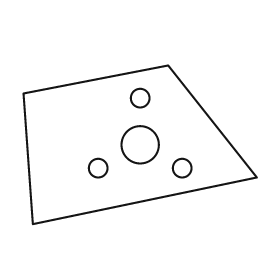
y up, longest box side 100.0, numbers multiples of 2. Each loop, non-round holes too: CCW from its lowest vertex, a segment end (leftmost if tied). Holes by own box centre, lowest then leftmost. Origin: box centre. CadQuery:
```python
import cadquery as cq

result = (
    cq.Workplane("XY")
    .moveTo(-46.0, -34.0)
    .lineTo(50.0, -14.0)
    .lineTo(12.0, 34.0)
    .lineTo(-50.0, 22.0)
    .close()
    .moveTo(-18.0, -10.0)
    .circle(4.0)
    .moveTo(18.0, -10.0)
    .circle(4.0)
    .moveTo(0.0, 0.0)
    .circle(8.0)
    .moveTo(0.0, 20.0)
    .circle(4.0)
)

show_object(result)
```